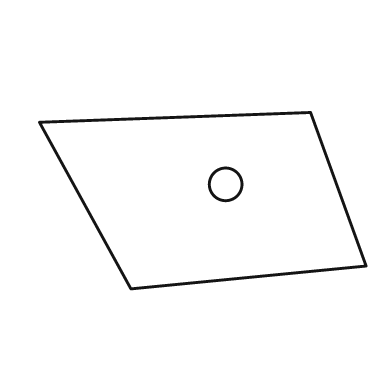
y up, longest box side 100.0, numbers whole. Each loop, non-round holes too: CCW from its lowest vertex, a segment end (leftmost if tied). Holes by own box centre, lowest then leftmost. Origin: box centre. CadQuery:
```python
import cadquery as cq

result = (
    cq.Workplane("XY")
    .moveTo(-22.0, -27.0)
    .lineTo(50.0, -20.0)
    .lineTo(33.0, 27.0)
    .lineTo(-50.0, 24.0)
    .close()
    .moveTo(7.0, 5.0)
    .circle(5.0)
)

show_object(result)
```